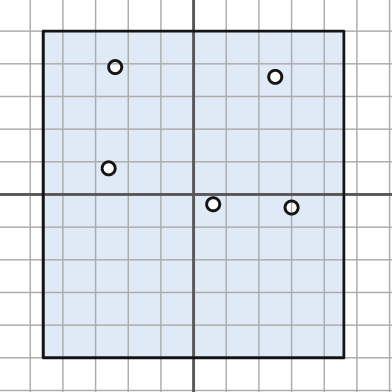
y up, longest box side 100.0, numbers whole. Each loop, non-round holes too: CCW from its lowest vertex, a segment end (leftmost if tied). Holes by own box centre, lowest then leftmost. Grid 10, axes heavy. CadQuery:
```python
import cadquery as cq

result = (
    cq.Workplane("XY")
    .moveTo(-46.0, -50.0)
    .lineTo(46.0, -50.0)
    .lineTo(46.0, 50.0)
    .lineTo(-46.0, 50.0)
    .close()
    .moveTo(30.0, -4.0)
    .circle(2.0)
    .moveTo(6.0, -3.0)
    .circle(2.0)
    .moveTo(-26.0, 8.0)
    .circle(2.0)
    .moveTo(25.0, 36.0)
    .circle(2.0)
    .moveTo(-24.0, 39.0)
    .circle(2.0)
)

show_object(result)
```